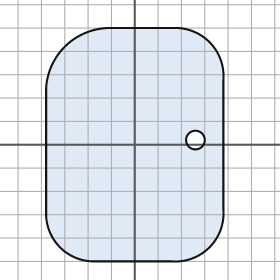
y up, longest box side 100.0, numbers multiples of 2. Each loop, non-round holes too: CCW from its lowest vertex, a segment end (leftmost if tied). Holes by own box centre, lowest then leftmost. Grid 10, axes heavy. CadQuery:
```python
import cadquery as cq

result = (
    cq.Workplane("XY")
    .moveTo(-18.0, -50.0)
    .lineTo(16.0, -50.0)
    .threePointArc((32.0, -44.0), (38.0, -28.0))
    .lineTo(38.0, 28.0)
    .threePointArc((32.0, 44.0), (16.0, 50.0))
    .lineTo(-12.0, 50.0)
    .threePointArc((-30.0, 42.0), (-38.0, 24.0))
    .lineTo(-38.0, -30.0)
    .threePointArc((-32.0, -44.0), (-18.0, -50.0))
    .close()
    .moveTo(26.0, 2.0)
    .circle(4.0)
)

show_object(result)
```